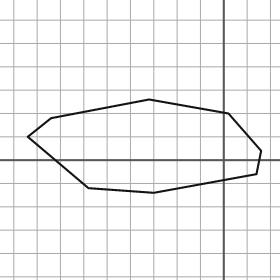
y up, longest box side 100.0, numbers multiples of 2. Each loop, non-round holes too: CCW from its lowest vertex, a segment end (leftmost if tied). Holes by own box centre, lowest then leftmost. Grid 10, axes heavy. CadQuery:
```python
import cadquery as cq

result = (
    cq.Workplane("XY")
    .moveTo(-30.0, -14.0)
    .lineTo(14.0, -6.0)
    .lineTo(16.0, 4.0)
    .lineTo(2.0, 20.0)
    .lineTo(-32.0, 26.0)
    .lineTo(-74.0, 18.0)
    .lineTo(-84.0, 10.0)
    .lineTo(-58.0, -12.0)
    .close()
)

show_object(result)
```